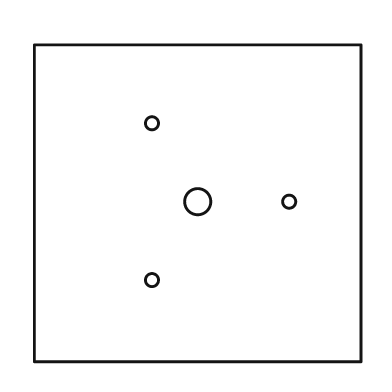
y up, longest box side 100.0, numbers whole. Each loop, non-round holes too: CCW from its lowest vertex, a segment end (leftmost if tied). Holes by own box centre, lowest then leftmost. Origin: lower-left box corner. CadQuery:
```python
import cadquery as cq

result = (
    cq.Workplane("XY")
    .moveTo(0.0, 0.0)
    .lineTo(100.0, 0.0)
    .lineTo(100.0, 97.0)
    .lineTo(0.0, 97.0)
    .close()
    .moveTo(36.0, 25.0)
    .circle(2.0)
    .moveTo(50.0, 49.0)
    .circle(4.0)
    .moveTo(78.0, 49.0)
    .circle(2.0)
    .moveTo(36.0, 73.0)
    .circle(2.0)
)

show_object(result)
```